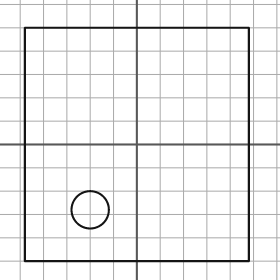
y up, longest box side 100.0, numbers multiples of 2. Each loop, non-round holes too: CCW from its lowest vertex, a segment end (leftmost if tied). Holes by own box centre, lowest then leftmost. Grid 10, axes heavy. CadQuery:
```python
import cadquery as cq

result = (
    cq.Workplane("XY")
    .moveTo(-48.0, -50.0)
    .lineTo(48.0, -50.0)
    .lineTo(48.0, 50.0)
    .lineTo(-48.0, 50.0)
    .close()
    .moveTo(-20.0, -28.0)
    .circle(8.0)
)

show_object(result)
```